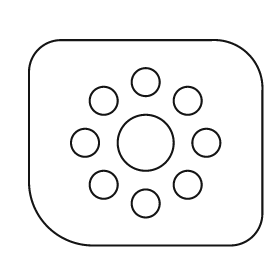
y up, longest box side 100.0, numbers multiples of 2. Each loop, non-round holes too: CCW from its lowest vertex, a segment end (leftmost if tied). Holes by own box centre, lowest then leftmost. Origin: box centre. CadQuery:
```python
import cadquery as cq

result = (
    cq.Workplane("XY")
    .moveTo(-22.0, -44.0)
    .lineTo(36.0, -44.0)
    .threePointArc((46.0, -40.0), (50.0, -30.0))
    .lineTo(50.0, 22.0)
    .threePointArc((44.0, 38.0), (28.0, 44.0))
    .lineTo(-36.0, 44.0)
    .threePointArc((-46.0, 40.0), (-50.0, 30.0))
    .lineTo(-50.0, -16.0)
    .threePointArc((-42.0, -36.0), (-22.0, -44.0))
    .close()
    .moveTo(0.0, -26.0)
    .circle(6.0)
    .moveTo(-18.0, -18.0)
    .circle(6.0)
    .moveTo(18.0, -18.0)
    .circle(6.0)
    .moveTo(-26.0, 0.0)
    .circle(6.0)
    .moveTo(0.0, 0.0)
    .circle(12.0)
    .moveTo(26.0, 0.0)
    .circle(6.0)
    .moveTo(-18.0, 18.0)
    .circle(6.0)
    .moveTo(18.0, 18.0)
    .circle(6.0)
    .moveTo(0.0, 26.0)
    .circle(6.0)
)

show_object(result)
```